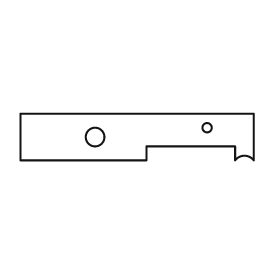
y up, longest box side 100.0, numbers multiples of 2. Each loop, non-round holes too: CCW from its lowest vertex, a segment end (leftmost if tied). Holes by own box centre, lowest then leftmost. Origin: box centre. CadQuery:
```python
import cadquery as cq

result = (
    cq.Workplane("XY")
    .moveTo(-50.0, -10.0)
    .lineTo(4.0, -10.0)
    .lineTo(4.0, -4.0)
    .lineTo(42.0, -4.0)
    .lineTo(42.0, -10.0)
    .threePointArc((46.0, -8.0), (50.0, -10.0))
    .lineTo(50.0, 10.0)
    .lineTo(-50.0, 10.0)
    .close()
    .moveTo(-18.0, 0.0)
    .circle(4.0)
    .moveTo(30.0, 4.0)
    .circle(2.0)
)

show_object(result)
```